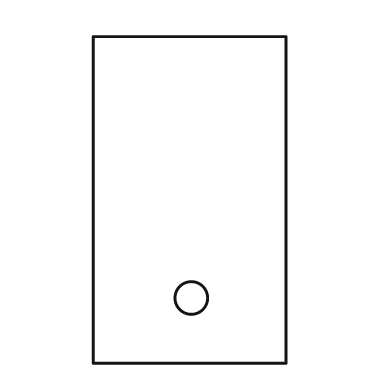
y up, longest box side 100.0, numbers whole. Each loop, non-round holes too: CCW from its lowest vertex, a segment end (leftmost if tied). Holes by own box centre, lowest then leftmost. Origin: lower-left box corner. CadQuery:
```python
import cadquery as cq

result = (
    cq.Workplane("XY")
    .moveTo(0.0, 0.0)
    .lineTo(59.0, 0.0)
    .lineTo(59.0, 100.0)
    .lineTo(0.0, 100.0)
    .close()
    .moveTo(30.0, 20.0)
    .circle(5.0)
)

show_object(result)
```